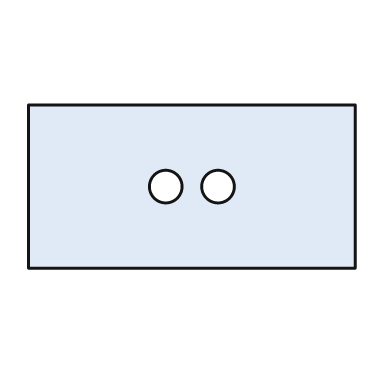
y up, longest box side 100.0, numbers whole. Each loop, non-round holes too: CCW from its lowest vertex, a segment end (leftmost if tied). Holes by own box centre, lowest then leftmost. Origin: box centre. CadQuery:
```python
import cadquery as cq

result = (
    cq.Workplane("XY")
    .moveTo(-50.0, -25.0)
    .lineTo(50.0, -25.0)
    .lineTo(50.0, 25.0)
    .lineTo(-50.0, 25.0)
    .close()
    .moveTo(-8.0, 0.0)
    .circle(5.0)
    .moveTo(8.0, 0.0)
    .circle(5.0)
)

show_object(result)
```